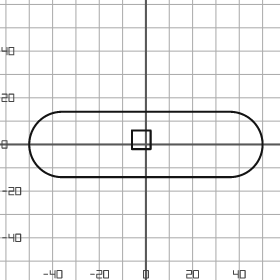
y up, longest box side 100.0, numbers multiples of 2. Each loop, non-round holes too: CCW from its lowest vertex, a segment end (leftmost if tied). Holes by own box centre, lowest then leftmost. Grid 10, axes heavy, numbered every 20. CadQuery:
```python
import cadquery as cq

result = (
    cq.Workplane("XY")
    .moveTo(-36.0, -14.0)
    .lineTo(36.0, -14.0)
    .threePointArc((50.0, 0.0), (36.0, 14.0))
    .lineTo(-36.0, 14.0)
    .threePointArc((-50.0, 0.0), (-36.0, -14.0))
    .close()
    .moveTo(-6.0, -2.0)
    .lineTo(2.0, -2.0)
    .lineTo(2.0, 6.0)
    .lineTo(-6.0, 6.0)
    .close()
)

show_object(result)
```